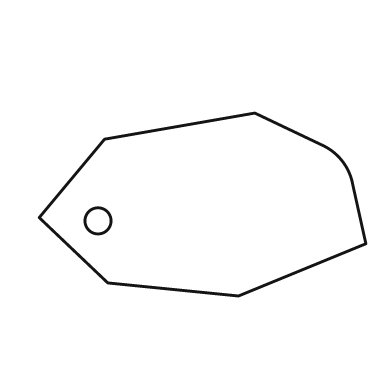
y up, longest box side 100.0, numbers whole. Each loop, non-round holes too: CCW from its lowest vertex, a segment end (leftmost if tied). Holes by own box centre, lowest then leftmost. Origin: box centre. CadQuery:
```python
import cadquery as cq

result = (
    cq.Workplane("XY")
    .moveTo(11.0, -28.0)
    .lineTo(50.0, -12.0)
    .lineTo(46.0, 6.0)
    .threePointArc((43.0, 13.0), (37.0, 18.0))
    .lineTo(16.0, 28.0)
    .lineTo(-30.0, 20.0)
    .lineTo(-50.0, -4.0)
    .lineTo(-29.0, -24.0)
    .close()
    .moveTo(-32.0, -5.0)
    .circle(4.0)
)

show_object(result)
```